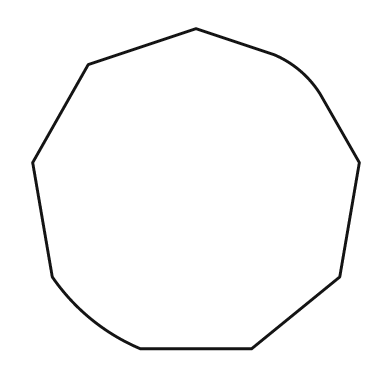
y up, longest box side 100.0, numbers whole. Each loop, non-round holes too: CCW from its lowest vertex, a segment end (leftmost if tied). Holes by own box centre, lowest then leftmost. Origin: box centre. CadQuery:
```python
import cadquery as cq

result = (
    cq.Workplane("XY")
    .moveTo(-17.0, -49.0)
    .lineTo(17.0, -49.0)
    .lineTo(44.0, -27.0)
    .lineTo(50.0, 8.0)
    .lineTo(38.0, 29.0)
    .threePointArc((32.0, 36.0), (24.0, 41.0))
    .lineTo(0.0, 49.0)
    .lineTo(-33.0, 38.0)
    .lineTo(-50.0, 8.0)
    .lineTo(-44.0, -27.0)
    .threePointArc((-32.0, -40.0), (-17.0, -49.0))
    .close()
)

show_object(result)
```